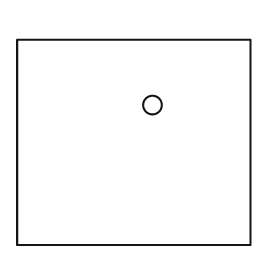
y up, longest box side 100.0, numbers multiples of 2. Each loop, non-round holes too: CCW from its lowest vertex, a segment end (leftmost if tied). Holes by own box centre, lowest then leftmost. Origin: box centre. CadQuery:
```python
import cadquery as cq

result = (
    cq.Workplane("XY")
    .moveTo(-50.0, -44.0)
    .lineTo(50.0, -44.0)
    .lineTo(50.0, 44.0)
    .lineTo(-50.0, 44.0)
    .close()
    .moveTo(8.0, 16.0)
    .circle(4.0)
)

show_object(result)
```